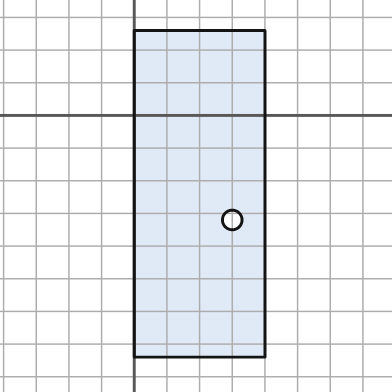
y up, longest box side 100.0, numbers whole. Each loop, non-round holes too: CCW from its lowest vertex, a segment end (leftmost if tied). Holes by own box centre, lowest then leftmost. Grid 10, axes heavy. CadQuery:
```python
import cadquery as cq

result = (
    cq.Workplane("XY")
    .moveTo(0.0, -74.0)
    .lineTo(40.0, -74.0)
    .lineTo(40.0, 26.0)
    .lineTo(0.0, 26.0)
    .close()
    .moveTo(30.0, -32.0)
    .circle(3.0)
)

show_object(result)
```